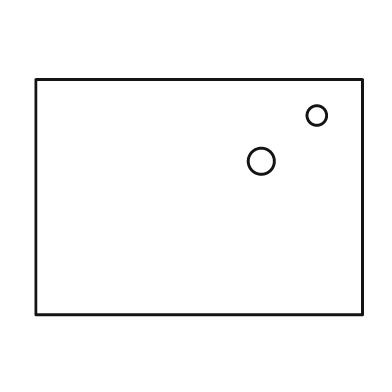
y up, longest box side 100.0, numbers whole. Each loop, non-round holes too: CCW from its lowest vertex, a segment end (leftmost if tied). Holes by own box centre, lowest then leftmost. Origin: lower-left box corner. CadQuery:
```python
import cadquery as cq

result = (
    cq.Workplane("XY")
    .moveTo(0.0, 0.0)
    .lineTo(100.0, 0.0)
    .lineTo(100.0, 72.0)
    .lineTo(0.0, 72.0)
    .close()
    .moveTo(69.0, 47.0)
    .circle(4.0)
    .moveTo(86.0, 61.0)
    .circle(3.0)
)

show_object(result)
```